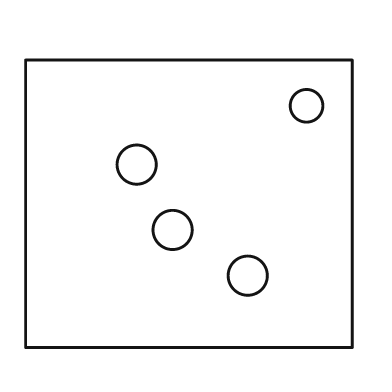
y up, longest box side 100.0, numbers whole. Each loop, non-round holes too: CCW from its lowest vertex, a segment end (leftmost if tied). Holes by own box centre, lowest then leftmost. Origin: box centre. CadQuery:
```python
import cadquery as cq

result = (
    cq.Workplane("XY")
    .moveTo(-50.0, -44.0)
    .lineTo(50.0, -44.0)
    .lineTo(50.0, 44.0)
    .lineTo(-50.0, 44.0)
    .close()
    .moveTo(18.0, -22.0)
    .circle(6.0)
    .moveTo(-5.0, -8.0)
    .circle(6.0)
    .moveTo(-16.0, 12.0)
    .circle(6.0)
    .moveTo(36.0, 30.0)
    .circle(5.0)
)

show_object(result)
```